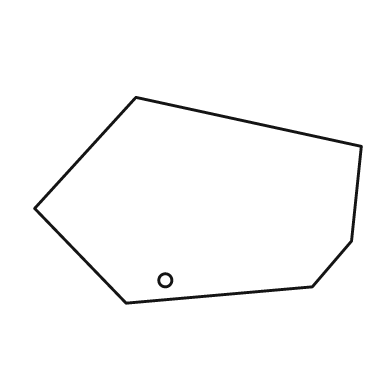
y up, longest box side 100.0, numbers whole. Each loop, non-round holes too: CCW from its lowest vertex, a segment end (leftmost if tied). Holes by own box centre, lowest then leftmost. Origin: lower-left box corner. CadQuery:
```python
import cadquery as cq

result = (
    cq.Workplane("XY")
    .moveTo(28.0, 0.0)
    .lineTo(85.0, 5.0)
    .lineTo(97.0, 19.0)
    .lineTo(100.0, 48.0)
    .lineTo(31.0, 63.0)
    .lineTo(0.0, 29.0)
    .close()
    .moveTo(40.0, 7.0)
    .circle(2.0)
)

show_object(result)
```